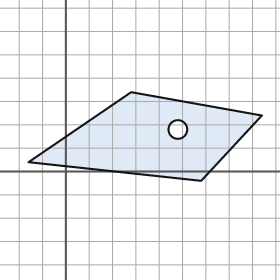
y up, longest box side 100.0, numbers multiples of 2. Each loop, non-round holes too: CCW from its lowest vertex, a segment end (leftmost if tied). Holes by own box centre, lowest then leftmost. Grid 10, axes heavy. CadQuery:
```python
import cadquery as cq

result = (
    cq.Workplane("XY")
    .moveTo(58.0, -4.0)
    .lineTo(84.0, 24.0)
    .lineTo(28.0, 34.0)
    .lineTo(-16.0, 4.0)
    .close()
    .moveTo(48.0, 18.0)
    .circle(4.0)
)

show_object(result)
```